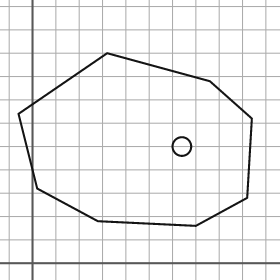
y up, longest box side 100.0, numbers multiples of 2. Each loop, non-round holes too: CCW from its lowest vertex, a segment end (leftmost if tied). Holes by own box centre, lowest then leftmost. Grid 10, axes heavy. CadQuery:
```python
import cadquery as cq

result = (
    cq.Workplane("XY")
    .moveTo(70.0, 16.0)
    .lineTo(92.0, 28.0)
    .lineTo(94.0, 62.0)
    .lineTo(76.0, 78.0)
    .lineTo(32.0, 90.0)
    .lineTo(-6.0, 64.0)
    .lineTo(2.0, 32.0)
    .lineTo(28.0, 18.0)
    .close()
    .moveTo(64.0, 50.0)
    .circle(4.0)
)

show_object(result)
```